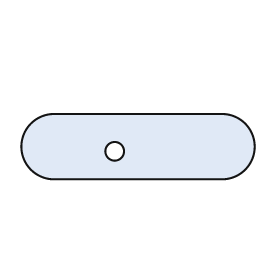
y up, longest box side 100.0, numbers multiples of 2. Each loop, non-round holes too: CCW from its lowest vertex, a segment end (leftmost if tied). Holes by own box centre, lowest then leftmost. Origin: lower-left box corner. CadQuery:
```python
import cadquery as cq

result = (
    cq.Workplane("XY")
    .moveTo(14.0, 0.0)
    .lineTo(86.0, 0.0)
    .threePointArc((100.0, 14.0), (86.0, 28.0))
    .lineTo(14.0, 28.0)
    .threePointArc((0.0, 14.0), (14.0, 0.0))
    .close()
    .moveTo(40.0, 12.0)
    .circle(4.0)
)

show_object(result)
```